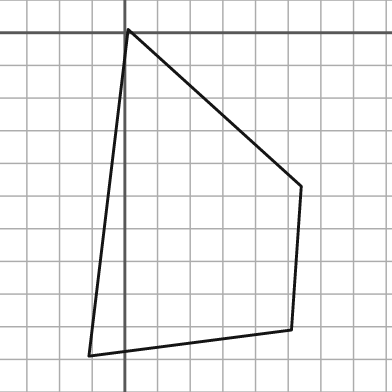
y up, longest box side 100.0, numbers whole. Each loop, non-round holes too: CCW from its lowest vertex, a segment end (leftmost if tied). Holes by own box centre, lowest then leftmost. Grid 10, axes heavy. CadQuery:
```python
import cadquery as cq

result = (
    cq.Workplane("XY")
    .moveTo(-11.0, -99.0)
    .lineTo(51.0, -91.0)
    .lineTo(54.0, -47.0)
    .lineTo(1.0, 1.0)
    .close()
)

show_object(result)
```